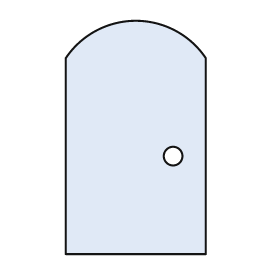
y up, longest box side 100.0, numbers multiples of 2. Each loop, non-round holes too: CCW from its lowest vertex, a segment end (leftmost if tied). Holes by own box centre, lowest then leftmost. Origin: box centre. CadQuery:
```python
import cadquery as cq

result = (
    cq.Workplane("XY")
    .moveTo(-30.0, -50.0)
    .lineTo(30.0, -50.0)
    .lineTo(30.0, 34.0)
    .threePointArc((0.0, 50.0), (-30.0, 34.0))
    .close()
    .moveTo(16.0, -8.0)
    .circle(4.0)
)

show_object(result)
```